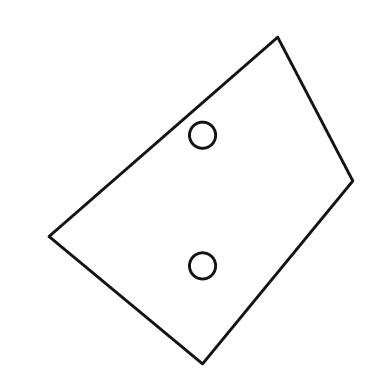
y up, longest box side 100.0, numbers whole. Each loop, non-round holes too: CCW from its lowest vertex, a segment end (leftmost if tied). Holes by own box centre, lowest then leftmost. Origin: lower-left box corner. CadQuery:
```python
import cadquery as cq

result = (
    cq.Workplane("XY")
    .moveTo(47.0, 0.0)
    .lineTo(93.0, 56.0)
    .lineTo(70.0, 100.0)
    .lineTo(0.0, 39.0)
    .close()
    .moveTo(47.0, 30.0)
    .circle(4.0)
    .moveTo(47.0, 70.0)
    .circle(4.0)
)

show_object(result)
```